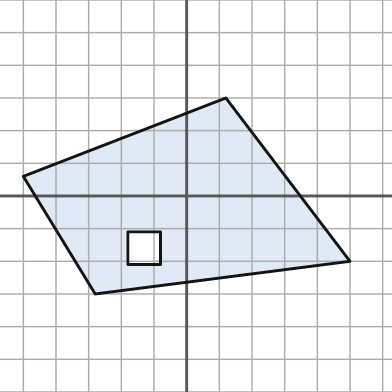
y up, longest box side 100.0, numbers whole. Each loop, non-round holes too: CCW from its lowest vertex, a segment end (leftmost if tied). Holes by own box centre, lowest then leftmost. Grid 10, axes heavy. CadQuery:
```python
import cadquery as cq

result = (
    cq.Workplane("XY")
    .moveTo(-28.0, -30.0)
    .lineTo(50.0, -20.0)
    .lineTo(12.0, 30.0)
    .lineTo(-50.0, 6.0)
    .close()
    .moveTo(-18.0, -21.0)
    .lineTo(-8.0, -21.0)
    .lineTo(-8.0, -11.0)
    .lineTo(-18.0, -11.0)
    .close()
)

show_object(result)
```